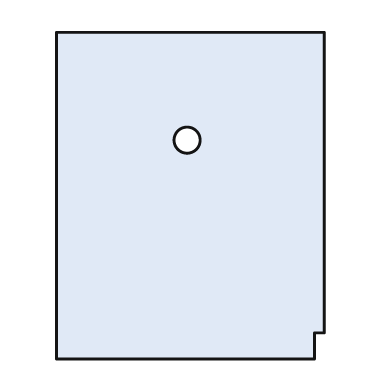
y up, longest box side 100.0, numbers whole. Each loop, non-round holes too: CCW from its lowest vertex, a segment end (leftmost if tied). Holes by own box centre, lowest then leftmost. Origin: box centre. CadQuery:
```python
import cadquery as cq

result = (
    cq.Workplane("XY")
    .moveTo(-41.0, -50.0)
    .lineTo(38.0, -50.0)
    .lineTo(38.0, -42.0)
    .lineTo(41.0, -42.0)
    .lineTo(41.0, 50.0)
    .lineTo(-41.0, 50.0)
    .close()
    .moveTo(-1.0, 17.0)
    .circle(4.0)
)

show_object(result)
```